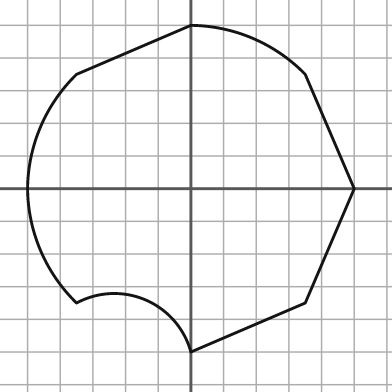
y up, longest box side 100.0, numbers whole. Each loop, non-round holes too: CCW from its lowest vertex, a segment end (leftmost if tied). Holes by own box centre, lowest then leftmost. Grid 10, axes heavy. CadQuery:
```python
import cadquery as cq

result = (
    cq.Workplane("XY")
    .moveTo(0.0, -50.0)
    .lineTo(35.0, -35.0)
    .lineTo(50.0, 0.0)
    .lineTo(35.0, 35.0)
    .threePointArc((19.0, 46.0), (0.0, 50.0))
    .lineTo(-35.0, 35.0)
    .threePointArc((-46.0, 19.0), (-50.0, 0.0))
    .threePointArc((-46.0, -19.0), (-35.0, -35.0))
    .threePointArc((-14.0, -34.0), (0.0, -50.0))
    .close()
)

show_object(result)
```